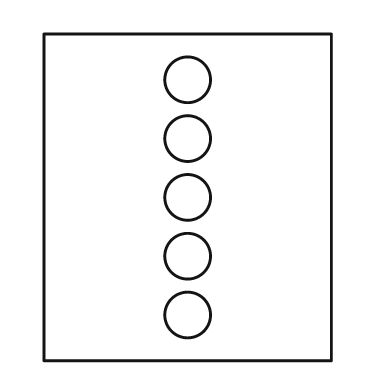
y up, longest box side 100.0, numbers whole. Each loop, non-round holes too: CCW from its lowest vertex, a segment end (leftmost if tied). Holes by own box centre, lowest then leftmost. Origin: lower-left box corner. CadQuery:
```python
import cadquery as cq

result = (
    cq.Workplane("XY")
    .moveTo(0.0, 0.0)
    .lineTo(88.0, 0.0)
    .lineTo(88.0, 100.0)
    .lineTo(0.0, 100.0)
    .close()
    .moveTo(44.0, 14.0)
    .circle(7.0)
    .moveTo(44.0, 32.0)
    .circle(7.0)
    .moveTo(44.0, 50.0)
    .circle(7.0)
    .moveTo(44.0, 68.0)
    .circle(7.0)
    .moveTo(44.0, 86.0)
    .circle(7.0)
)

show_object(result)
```